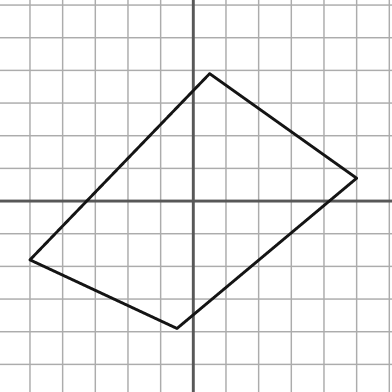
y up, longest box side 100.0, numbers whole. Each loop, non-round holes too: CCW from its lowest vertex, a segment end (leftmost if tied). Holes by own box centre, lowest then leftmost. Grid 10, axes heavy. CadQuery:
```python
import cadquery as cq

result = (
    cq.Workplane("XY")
    .moveTo(-5.0, -39.0)
    .lineTo(50.0, 7.0)
    .lineTo(5.0, 39.0)
    .lineTo(-50.0, -18.0)
    .close()
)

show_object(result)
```